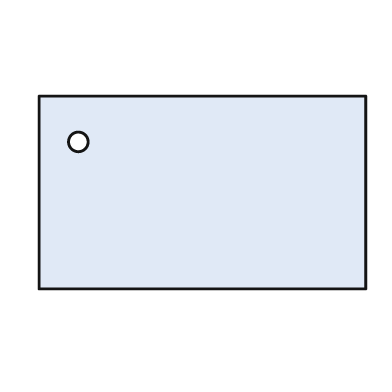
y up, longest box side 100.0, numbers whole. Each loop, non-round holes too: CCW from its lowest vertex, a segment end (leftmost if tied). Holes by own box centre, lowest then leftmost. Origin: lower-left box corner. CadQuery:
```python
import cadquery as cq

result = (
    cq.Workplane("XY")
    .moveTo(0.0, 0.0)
    .lineTo(100.0, 0.0)
    .lineTo(100.0, 59.0)
    .lineTo(0.0, 59.0)
    .close()
    .moveTo(12.0, 45.0)
    .circle(3.0)
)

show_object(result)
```